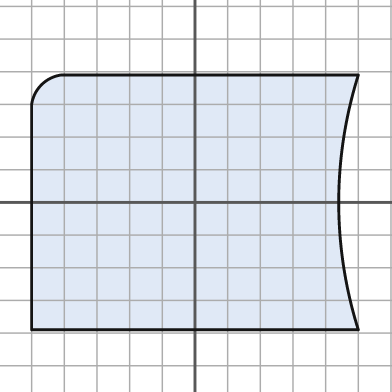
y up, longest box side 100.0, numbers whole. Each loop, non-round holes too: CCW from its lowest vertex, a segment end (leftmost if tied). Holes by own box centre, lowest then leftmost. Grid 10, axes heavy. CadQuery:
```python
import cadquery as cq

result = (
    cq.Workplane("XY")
    .moveTo(-50.0, -39.0)
    .lineTo(50.0, -39.0)
    .threePointArc((44.0, 0.0), (50.0, 39.0))
    .lineTo(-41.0, 39.0)
    .threePointArc((-47.0, 36.0), (-50.0, 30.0))
    .close()
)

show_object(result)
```